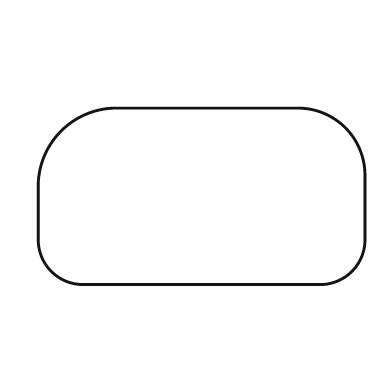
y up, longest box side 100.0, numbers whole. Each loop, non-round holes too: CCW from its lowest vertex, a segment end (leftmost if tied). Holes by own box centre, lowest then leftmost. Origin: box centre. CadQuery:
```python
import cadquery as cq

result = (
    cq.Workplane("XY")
    .moveTo(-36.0, -27.0)
    .lineTo(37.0, -27.0)
    .threePointArc((46.0, -23.0), (50.0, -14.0))
    .lineTo(50.0, 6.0)
    .threePointArc((44.0, 21.0), (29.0, 27.0))
    .lineTo(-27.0, 27.0)
    .threePointArc((-43.0, 20.0), (-50.0, 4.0))
    .lineTo(-50.0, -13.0)
    .threePointArc((-46.0, -23.0), (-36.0, -27.0))
    .close()
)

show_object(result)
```